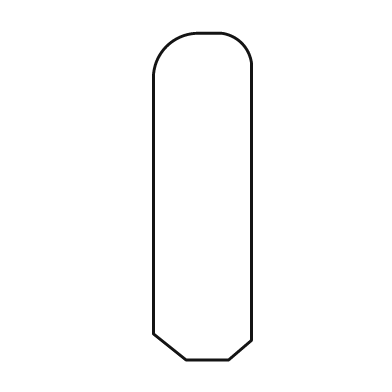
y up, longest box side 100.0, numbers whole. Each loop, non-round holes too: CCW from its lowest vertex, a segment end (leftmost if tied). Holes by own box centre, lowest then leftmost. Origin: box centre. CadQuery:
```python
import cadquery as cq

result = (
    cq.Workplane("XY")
    .moveTo(-5.0, -50.0)
    .lineTo(8.0, -50.0)
    .lineTo(15.0, -44.0)
    .lineTo(15.0, 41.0)
    .threePointArc((12.0, 47.0), (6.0, 50.0))
    .lineTo(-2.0, 50.0)
    .threePointArc((-11.0, 46.0), (-15.0, 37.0))
    .lineTo(-15.0, -42.0)
    .close()
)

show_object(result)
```